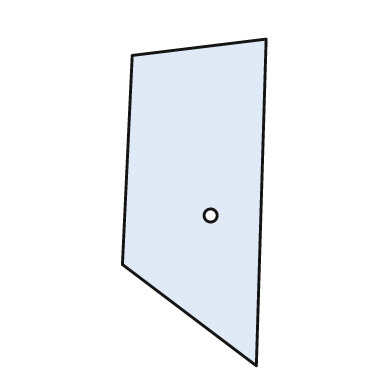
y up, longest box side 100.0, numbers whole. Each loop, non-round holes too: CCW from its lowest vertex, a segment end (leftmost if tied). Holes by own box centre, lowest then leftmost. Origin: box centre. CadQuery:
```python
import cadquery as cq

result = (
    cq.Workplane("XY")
    .moveTo(19.0, -50.0)
    .lineTo(22.0, 50.0)
    .lineTo(-19.0, 45.0)
    .lineTo(-22.0, -19.0)
    .close()
    .moveTo(5.0, -4.0)
    .circle(2.0)
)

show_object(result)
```